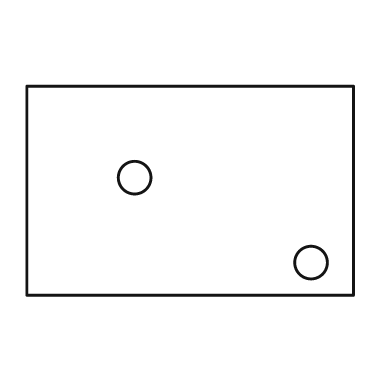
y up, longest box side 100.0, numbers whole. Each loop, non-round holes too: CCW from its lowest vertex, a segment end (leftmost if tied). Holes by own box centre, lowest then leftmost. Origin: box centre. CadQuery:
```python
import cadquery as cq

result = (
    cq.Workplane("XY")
    .moveTo(-50.0, -32.0)
    .lineTo(50.0, -32.0)
    .lineTo(50.0, 32.0)
    .lineTo(-50.0, 32.0)
    .close()
    .moveTo(37.0, -22.0)
    .circle(5.0)
    .moveTo(-17.0, 4.0)
    .circle(5.0)
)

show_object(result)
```